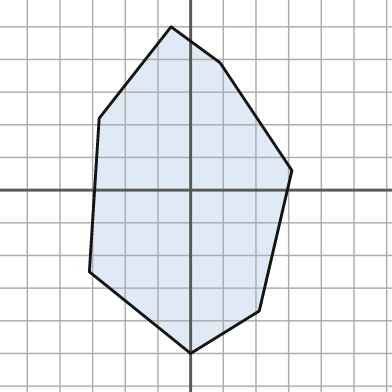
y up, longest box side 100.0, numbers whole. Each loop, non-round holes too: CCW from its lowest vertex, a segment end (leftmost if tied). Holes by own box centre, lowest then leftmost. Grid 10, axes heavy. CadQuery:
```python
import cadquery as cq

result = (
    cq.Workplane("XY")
    .moveTo(0.0, -50.0)
    .lineTo(21.0, -37.0)
    .lineTo(31.0, 6.0)
    .lineTo(9.0, 39.0)
    .lineTo(-6.0, 50.0)
    .lineTo(-28.0, 22.0)
    .lineTo(-31.0, -25.0)
    .close()
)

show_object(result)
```